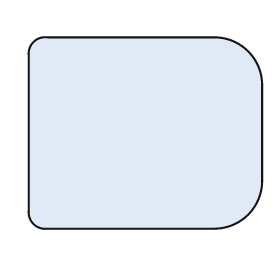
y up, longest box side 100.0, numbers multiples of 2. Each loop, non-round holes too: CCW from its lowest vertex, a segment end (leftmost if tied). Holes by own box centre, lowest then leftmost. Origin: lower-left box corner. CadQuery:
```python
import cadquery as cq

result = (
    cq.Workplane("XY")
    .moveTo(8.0, 0.0)
    .lineTo(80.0, 0.0)
    .threePointArc((94.0, 6.0), (100.0, 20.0))
    .lineTo(100.0, 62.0)
    .threePointArc((94.0, 76.0), (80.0, 82.0))
    .lineTo(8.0, 82.0)
    .threePointArc((2.0, 80.0), (0.0, 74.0))
    .lineTo(0.0, 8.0)
    .threePointArc((2.0, 2.0), (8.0, 0.0))
    .close()
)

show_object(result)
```